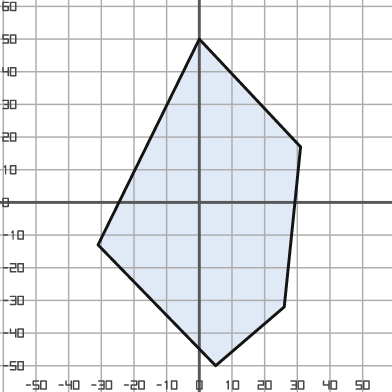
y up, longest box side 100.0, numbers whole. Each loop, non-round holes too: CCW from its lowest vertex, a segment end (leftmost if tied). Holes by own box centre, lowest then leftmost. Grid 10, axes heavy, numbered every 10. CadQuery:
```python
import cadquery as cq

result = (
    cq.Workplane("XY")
    .moveTo(5.0, -50.0)
    .lineTo(26.0, -32.0)
    .lineTo(31.0, 17.0)
    .lineTo(0.0, 50.0)
    .lineTo(-31.0, -13.0)
    .close()
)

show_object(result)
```